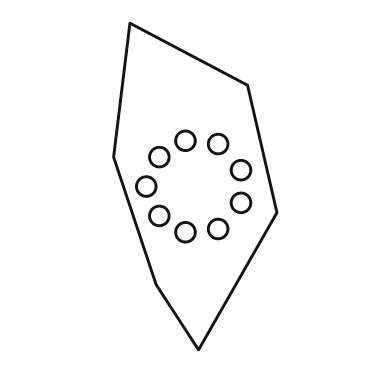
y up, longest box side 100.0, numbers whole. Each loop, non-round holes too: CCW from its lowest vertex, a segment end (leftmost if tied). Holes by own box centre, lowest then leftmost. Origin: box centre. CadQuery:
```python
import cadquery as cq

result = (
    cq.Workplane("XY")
    .moveTo(1.0, -50.0)
    .lineTo(25.0, -8.0)
    .lineTo(16.0, 31.0)
    .lineTo(-20.0, 50.0)
    .lineTo(-25.0, 9.0)
    .lineTo(-12.0, -30.0)
    .close()
    .moveTo(-3.0, -14.0)
    .circle(3.0)
    .moveTo(7.0, -13.0)
    .circle(3.0)
    .moveTo(-11.0, -9.0)
    .circle(3.0)
    .moveTo(14.0, -5.0)
    .circle(3.0)
    .moveTo(-15.0, 0.0)
    .circle(3.0)
    .moveTo(14.0, 5.0)
    .circle(3.0)
    .moveTo(-11.0, 9.0)
    .circle(3.0)
    .moveTo(7.0, 13.0)
    .circle(3.0)
    .moveTo(-3.0, 14.0)
    .circle(3.0)
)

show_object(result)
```